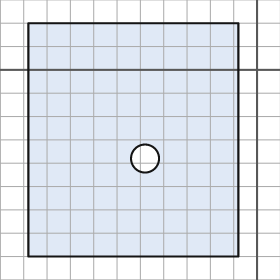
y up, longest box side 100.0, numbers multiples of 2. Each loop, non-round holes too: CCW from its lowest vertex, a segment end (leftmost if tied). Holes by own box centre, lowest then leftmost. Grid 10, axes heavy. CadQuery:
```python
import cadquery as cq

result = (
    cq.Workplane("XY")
    .moveTo(-98.0, -80.0)
    .lineTo(-8.0, -80.0)
    .lineTo(-8.0, 20.0)
    .lineTo(-98.0, 20.0)
    .close()
    .moveTo(-48.0, -38.0)
    .circle(6.0)
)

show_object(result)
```